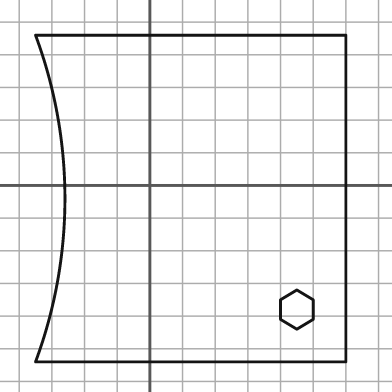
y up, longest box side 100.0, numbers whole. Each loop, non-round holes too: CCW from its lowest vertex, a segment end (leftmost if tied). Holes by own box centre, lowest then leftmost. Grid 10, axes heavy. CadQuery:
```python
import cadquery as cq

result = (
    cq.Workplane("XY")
    .moveTo(-35.0, -54.0)
    .lineTo(60.0, -54.0)
    .lineTo(60.0, 46.0)
    .lineTo(-35.0, 46.0)
    .threePointArc((-26.0, -4.0), (-35.0, -54.0))
    .close()
    .moveTo(45.0, -44.0)
    .lineTo(50.0, -41.0)
    .lineTo(50.0, -35.0)
    .lineTo(45.0, -32.0)
    .lineTo(40.0, -35.0)
    .lineTo(40.0, -41.0)
    .close()
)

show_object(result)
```